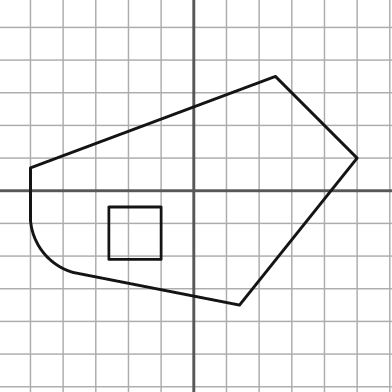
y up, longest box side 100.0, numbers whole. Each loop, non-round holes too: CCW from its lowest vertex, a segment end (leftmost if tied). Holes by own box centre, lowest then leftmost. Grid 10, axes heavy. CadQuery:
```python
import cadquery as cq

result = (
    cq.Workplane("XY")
    .moveTo(14.0, -35.0)
    .lineTo(50.0, 10.0)
    .lineTo(25.0, 35.0)
    .lineTo(-50.0, 7.0)
    .lineTo(-50.0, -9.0)
    .threePointArc((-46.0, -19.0), (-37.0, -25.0))
    .close()
    .moveTo(-26.0, -21.0)
    .lineTo(-10.0, -21.0)
    .lineTo(-10.0, -5.0)
    .lineTo(-26.0, -5.0)
    .close()
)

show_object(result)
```